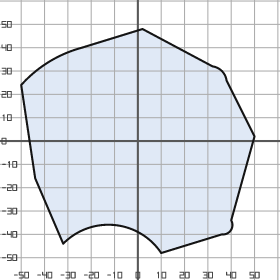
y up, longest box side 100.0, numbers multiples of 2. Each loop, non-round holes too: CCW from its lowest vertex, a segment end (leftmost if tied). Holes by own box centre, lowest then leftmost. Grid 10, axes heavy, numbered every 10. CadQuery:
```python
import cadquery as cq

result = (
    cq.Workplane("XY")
    .moveTo(10.0, -48.0)
    .lineTo(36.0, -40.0)
    .threePointArc((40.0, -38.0), (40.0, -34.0))
    .lineTo(50.0, 2.0)
    .lineTo(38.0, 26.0)
    .threePointArc((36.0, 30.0), (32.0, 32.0))
    .lineTo(2.0, 48.0)
    .lineTo(-24.0, 40.0)
    .threePointArc((-38.0, 34.0), (-50.0, 24.0))
    .lineTo(-44.0, -16.0)
    .lineTo(-32.0, -44.0)
    .threePointArc((-10.0, -36.0), (10.0, -48.0))
    .close()
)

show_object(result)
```